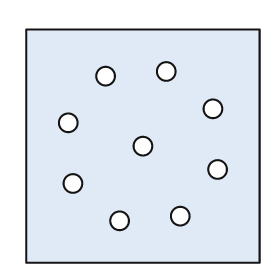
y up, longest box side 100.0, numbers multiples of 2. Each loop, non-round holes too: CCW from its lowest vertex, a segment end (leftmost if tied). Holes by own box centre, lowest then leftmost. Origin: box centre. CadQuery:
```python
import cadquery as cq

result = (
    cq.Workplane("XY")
    .moveTo(-50.0, -50.0)
    .lineTo(50.0, -50.0)
    .lineTo(50.0, 50.0)
    .lineTo(-50.0, 50.0)
    .close()
    .moveTo(-10.0, -32.0)
    .circle(4.0)
    .moveTo(16.0, -30.0)
    .circle(4.0)
    .moveTo(-30.0, -16.0)
    .circle(4.0)
    .moveTo(32.0, -10.0)
    .circle(4.0)
    .moveTo(0.0, 0.0)
    .circle(4.0)
    .moveTo(-32.0, 10.0)
    .circle(4.0)
    .moveTo(30.0, 16.0)
    .circle(4.0)
    .moveTo(-16.0, 30.0)
    .circle(4.0)
    .moveTo(10.0, 32.0)
    .circle(4.0)
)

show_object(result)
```